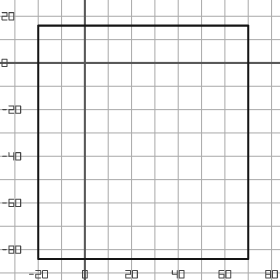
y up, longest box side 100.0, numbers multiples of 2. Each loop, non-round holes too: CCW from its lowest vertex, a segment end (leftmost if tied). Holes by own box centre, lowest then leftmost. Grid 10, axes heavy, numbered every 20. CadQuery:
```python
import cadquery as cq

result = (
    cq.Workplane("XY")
    .moveTo(-20.0, -84.0)
    .lineTo(70.0, -84.0)
    .lineTo(70.0, 16.0)
    .lineTo(-20.0, 16.0)
    .close()
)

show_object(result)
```